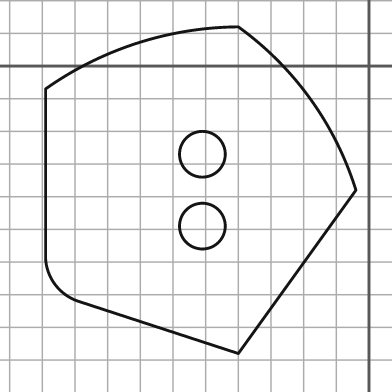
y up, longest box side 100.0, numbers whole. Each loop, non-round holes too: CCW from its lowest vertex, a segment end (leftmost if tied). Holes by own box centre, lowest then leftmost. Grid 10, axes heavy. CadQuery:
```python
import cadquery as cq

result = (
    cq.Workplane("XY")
    .moveTo(-40.0, -88.0)
    .lineTo(-4.0, -38.0)
    .threePointArc((-18.0, -10.0), (-40.0, 12.0))
    .threePointArc((-71.0, 7.0), (-99.0, -7.0))
    .lineTo(-99.0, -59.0)
    .threePointArc((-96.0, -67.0), (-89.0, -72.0))
    .close()
    .moveTo(-51.0, -49.0)
    .circle(7.0)
    .moveTo(-51.0, -27.0)
    .circle(7.0)
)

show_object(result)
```